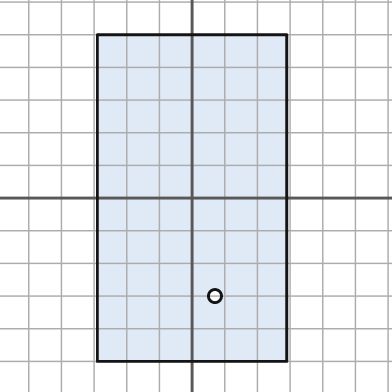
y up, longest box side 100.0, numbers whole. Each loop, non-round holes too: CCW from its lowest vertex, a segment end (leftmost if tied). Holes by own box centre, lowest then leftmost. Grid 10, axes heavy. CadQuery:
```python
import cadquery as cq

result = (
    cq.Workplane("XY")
    .moveTo(-29.0, -50.0)
    .lineTo(29.0, -50.0)
    .lineTo(29.0, 50.0)
    .lineTo(-29.0, 50.0)
    .close()
    .moveTo(7.0, -30.0)
    .circle(2.0)
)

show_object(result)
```